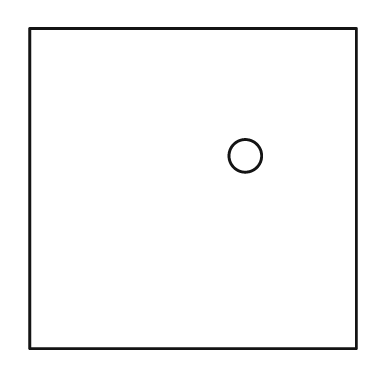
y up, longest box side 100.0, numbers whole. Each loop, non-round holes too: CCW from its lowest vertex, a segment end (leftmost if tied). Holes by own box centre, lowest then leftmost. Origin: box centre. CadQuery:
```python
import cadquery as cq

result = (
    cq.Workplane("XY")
    .moveTo(-50.0, -49.0)
    .lineTo(50.0, -49.0)
    .lineTo(50.0, 49.0)
    .lineTo(-50.0, 49.0)
    .close()
    .moveTo(16.0, 10.0)
    .circle(5.0)
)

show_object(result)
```